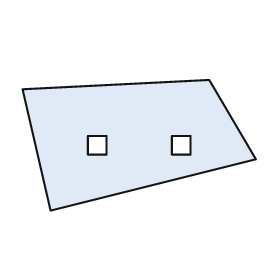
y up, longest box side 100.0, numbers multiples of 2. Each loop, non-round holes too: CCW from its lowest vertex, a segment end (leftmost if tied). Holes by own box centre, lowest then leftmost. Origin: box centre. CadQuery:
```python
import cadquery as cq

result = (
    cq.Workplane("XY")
    .moveTo(-38.0, -28.0)
    .lineTo(50.0, -6.0)
    .lineTo(30.0, 28.0)
    .lineTo(-50.0, 24.0)
    .close()
    .moveTo(-22.0, -4.0)
    .lineTo(-14.0, -4.0)
    .lineTo(-14.0, 4.0)
    .lineTo(-22.0, 4.0)
    .close()
    .moveTo(14.0, -4.0)
    .lineTo(22.0, -4.0)
    .lineTo(22.0, 4.0)
    .lineTo(14.0, 4.0)
    .close()
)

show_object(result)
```